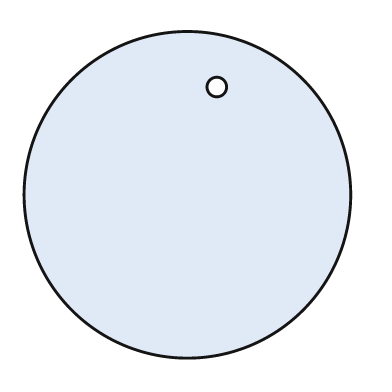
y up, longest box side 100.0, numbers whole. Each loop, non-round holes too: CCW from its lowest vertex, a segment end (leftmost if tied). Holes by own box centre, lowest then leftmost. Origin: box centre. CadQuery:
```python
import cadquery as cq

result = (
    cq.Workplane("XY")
    .moveTo(0.0, 0.0)
    .circle(50.0)
    .moveTo(9.0, 33.0)
    .circle(3.0)
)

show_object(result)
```